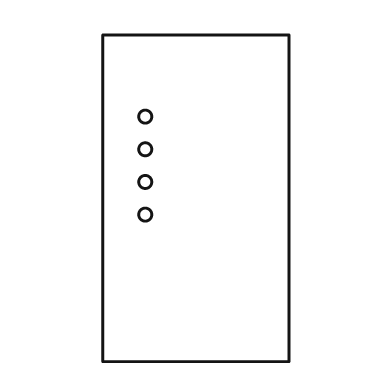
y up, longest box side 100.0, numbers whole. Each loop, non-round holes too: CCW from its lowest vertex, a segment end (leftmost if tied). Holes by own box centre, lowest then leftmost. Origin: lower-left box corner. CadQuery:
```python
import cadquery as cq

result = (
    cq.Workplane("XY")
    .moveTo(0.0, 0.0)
    .lineTo(57.0, 0.0)
    .lineTo(57.0, 100.0)
    .lineTo(0.0, 100.0)
    .close()
    .moveTo(13.0, 45.0)
    .circle(2.0)
    .moveTo(13.0, 55.0)
    .circle(2.0)
    .moveTo(13.0, 65.0)
    .circle(2.0)
    .moveTo(13.0, 75.0)
    .circle(2.0)
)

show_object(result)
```